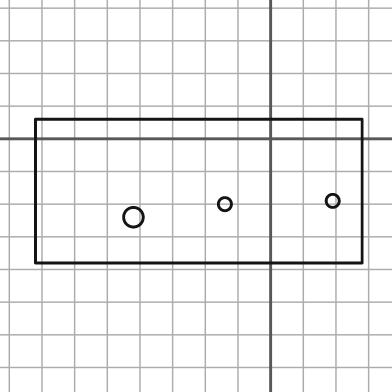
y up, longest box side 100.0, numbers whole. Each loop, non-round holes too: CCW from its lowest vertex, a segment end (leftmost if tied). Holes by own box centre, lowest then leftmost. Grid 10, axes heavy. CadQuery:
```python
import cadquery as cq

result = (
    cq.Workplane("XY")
    .moveTo(-72.0, -38.0)
    .lineTo(28.0, -38.0)
    .lineTo(28.0, 6.0)
    .lineTo(-72.0, 6.0)
    .close()
    .moveTo(-42.0, -24.0)
    .circle(3.0)
    .moveTo(-14.0, -20.0)
    .circle(2.0)
    .moveTo(19.0, -19.0)
    .circle(2.0)
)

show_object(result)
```